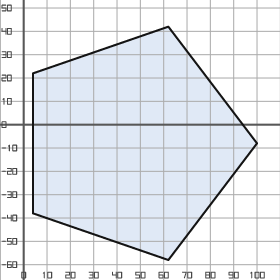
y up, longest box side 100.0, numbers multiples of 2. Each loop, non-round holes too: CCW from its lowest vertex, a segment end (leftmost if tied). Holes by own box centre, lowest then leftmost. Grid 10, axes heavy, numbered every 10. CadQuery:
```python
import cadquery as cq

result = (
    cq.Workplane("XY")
    .moveTo(62.0, -58.0)
    .lineTo(100.0, -8.0)
    .lineTo(62.0, 42.0)
    .lineTo(4.0, 22.0)
    .lineTo(4.0, -38.0)
    .close()
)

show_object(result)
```